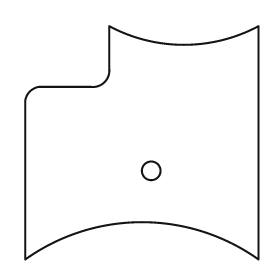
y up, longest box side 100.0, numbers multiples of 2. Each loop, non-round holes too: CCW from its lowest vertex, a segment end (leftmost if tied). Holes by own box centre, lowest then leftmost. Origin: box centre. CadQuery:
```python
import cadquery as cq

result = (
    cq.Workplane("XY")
    .moveTo(-50.0, -50.0)
    .threePointArc((0.0, -34.0), (50.0, -50.0))
    .lineTo(50.0, 50.0)
    .threePointArc((18.0, 42.0), (-14.0, 50.0))
    .lineTo(-14.0, 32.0)
    .threePointArc((-16.0, 26.0), (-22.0, 24.0))
    .lineTo(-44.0, 24.0)
    .threePointArc((-48.0, 22.0), (-50.0, 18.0))
    .close()
    .moveTo(4.0, -12.0)
    .circle(4.0)
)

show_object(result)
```